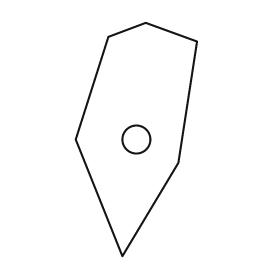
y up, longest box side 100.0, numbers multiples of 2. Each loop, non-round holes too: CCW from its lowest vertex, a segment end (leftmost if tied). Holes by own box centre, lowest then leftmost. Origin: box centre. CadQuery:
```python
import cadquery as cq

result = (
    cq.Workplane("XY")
    .moveTo(-6.0, -50.0)
    .lineTo(18.0, -10.0)
    .lineTo(26.0, 42.0)
    .lineTo(4.0, 50.0)
    .lineTo(-12.0, 44.0)
    .lineTo(-26.0, 0.0)
    .close()
    .moveTo(0.0, 0.0)
    .circle(6.0)
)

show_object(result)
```